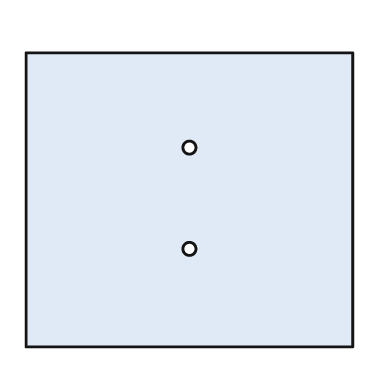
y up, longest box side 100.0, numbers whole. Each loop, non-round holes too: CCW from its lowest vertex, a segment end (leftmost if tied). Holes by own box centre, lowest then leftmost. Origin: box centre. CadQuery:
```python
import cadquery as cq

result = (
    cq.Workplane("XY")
    .moveTo(-50.0, -45.0)
    .lineTo(50.0, -45.0)
    .lineTo(50.0, 45.0)
    .lineTo(-50.0, 45.0)
    .close()
    .moveTo(0.0, -15.0)
    .circle(2.0)
    .moveTo(0.0, 16.0)
    .circle(2.0)
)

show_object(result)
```